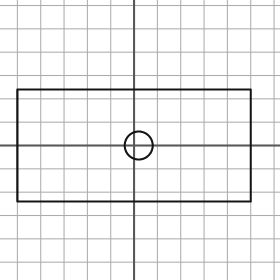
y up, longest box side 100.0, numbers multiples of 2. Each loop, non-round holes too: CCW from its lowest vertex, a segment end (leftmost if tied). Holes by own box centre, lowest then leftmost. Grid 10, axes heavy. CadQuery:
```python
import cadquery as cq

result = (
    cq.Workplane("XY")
    .moveTo(-50.0, -24.0)
    .lineTo(50.0, -24.0)
    .lineTo(50.0, 24.0)
    .lineTo(-50.0, 24.0)
    .close()
    .moveTo(2.0, 0.0)
    .circle(6.0)
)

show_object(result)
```